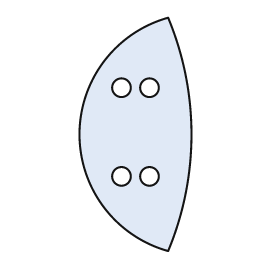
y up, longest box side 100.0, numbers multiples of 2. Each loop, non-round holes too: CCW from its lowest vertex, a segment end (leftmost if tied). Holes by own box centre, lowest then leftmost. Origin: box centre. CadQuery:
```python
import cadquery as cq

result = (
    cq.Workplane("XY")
    .moveTo(14.0, -50.0)
    .threePointArc((24.0, 0.0), (14.0, 50.0))
    .threePointArc((-24.0, 0.0), (14.0, -50.0))
    .close()
    .moveTo(-6.0, -18.0)
    .circle(4.0)
    .moveTo(6.0, -18.0)
    .circle(4.0)
    .moveTo(-6.0, 20.0)
    .circle(4.0)
    .moveTo(6.0, 20.0)
    .circle(4.0)
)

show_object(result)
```